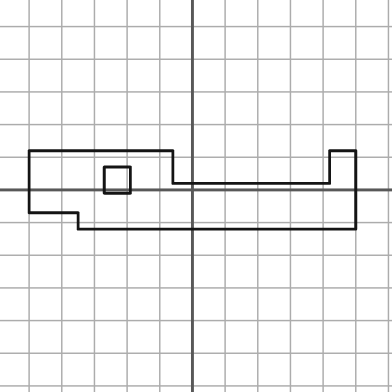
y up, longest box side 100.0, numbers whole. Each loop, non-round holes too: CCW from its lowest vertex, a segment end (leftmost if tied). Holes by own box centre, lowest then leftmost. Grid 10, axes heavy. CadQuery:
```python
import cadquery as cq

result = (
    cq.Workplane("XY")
    .moveTo(-35.0, -12.0)
    .lineTo(50.0, -12.0)
    .lineTo(50.0, 12.0)
    .lineTo(42.0, 12.0)
    .lineTo(42.0, 2.0)
    .lineTo(-6.0, 2.0)
    .lineTo(-6.0, 12.0)
    .lineTo(-50.0, 12.0)
    .lineTo(-50.0, -7.0)
    .lineTo(-35.0, -7.0)
    .close()
    .moveTo(-27.0, -1.0)
    .lineTo(-19.0, -1.0)
    .lineTo(-19.0, 7.0)
    .lineTo(-27.0, 7.0)
    .close()
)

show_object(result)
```